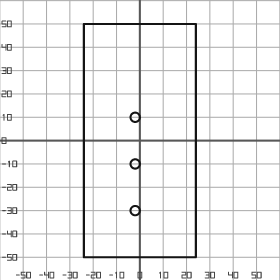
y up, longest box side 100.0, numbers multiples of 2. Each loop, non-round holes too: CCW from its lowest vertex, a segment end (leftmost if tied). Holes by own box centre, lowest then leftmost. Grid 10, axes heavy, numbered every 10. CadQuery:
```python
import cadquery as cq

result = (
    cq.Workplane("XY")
    .moveTo(-24.0, -50.0)
    .lineTo(24.0, -50.0)
    .lineTo(24.0, 50.0)
    .lineTo(-24.0, 50.0)
    .close()
    .moveTo(-2.0, -30.0)
    .circle(2.0)
    .moveTo(-2.0, -10.0)
    .circle(2.0)
    .moveTo(-2.0, 10.0)
    .circle(2.0)
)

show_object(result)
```